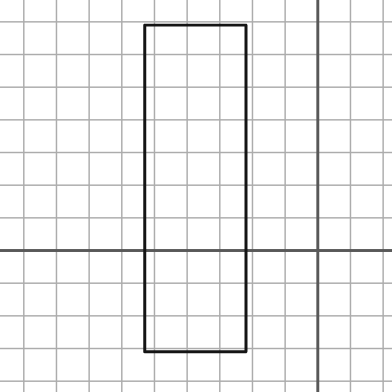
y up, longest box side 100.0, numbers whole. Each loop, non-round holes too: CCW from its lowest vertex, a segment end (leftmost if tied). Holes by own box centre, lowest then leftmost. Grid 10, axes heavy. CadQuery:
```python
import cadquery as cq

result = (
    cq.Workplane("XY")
    .moveTo(-53.0, -31.0)
    .lineTo(-22.0, -31.0)
    .lineTo(-22.0, 69.0)
    .lineTo(-53.0, 69.0)
    .close()
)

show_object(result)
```